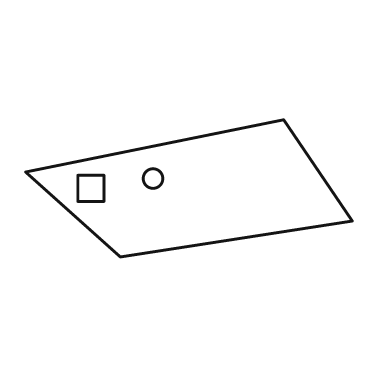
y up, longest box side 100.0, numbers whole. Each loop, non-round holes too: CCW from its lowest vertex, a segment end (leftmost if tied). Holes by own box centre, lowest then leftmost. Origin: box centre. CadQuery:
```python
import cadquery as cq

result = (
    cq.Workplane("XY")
    .moveTo(-21.0, -21.0)
    .lineTo(50.0, -10.0)
    .lineTo(29.0, 21.0)
    .lineTo(-50.0, 5.0)
    .close()
    .moveTo(-34.0, -4.0)
    .lineTo(-26.0, -4.0)
    .lineTo(-26.0, 4.0)
    .lineTo(-34.0, 4.0)
    .close()
    .moveTo(-11.0, 3.0)
    .circle(3.0)
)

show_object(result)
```